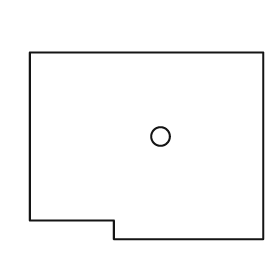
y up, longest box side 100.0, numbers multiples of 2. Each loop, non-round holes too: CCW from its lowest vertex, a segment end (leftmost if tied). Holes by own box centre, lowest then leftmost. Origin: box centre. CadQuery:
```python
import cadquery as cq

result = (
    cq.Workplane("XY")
    .moveTo(-14.0, -40.0)
    .lineTo(50.0, -40.0)
    .lineTo(50.0, 40.0)
    .lineTo(-50.0, 40.0)
    .lineTo(-50.0, -32.0)
    .lineTo(-14.0, -32.0)
    .close()
    .moveTo(6.0, 4.0)
    .circle(4.0)
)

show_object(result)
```